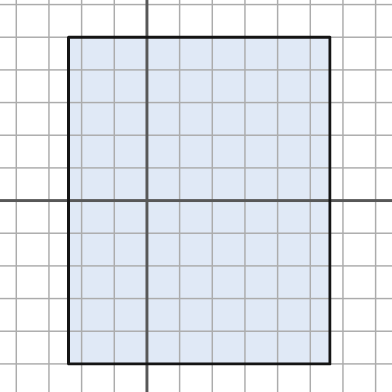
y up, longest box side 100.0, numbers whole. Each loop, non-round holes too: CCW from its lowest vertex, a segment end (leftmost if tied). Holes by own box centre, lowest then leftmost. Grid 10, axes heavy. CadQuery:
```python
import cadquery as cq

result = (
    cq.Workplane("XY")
    .moveTo(-24.0, -50.0)
    .lineTo(56.0, -50.0)
    .lineTo(56.0, 50.0)
    .lineTo(-24.0, 50.0)
    .close()
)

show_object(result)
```